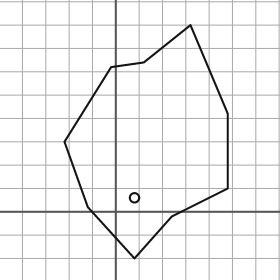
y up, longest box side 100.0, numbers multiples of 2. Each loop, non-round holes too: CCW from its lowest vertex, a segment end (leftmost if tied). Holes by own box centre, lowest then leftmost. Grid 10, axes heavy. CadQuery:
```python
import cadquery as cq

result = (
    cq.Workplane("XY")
    .moveTo(8.0, -20.0)
    .lineTo(24.0, -2.0)
    .lineTo(48.0, 10.0)
    .lineTo(48.0, 42.0)
    .lineTo(32.0, 80.0)
    .lineTo(12.0, 64.0)
    .lineTo(-2.0, 62.0)
    .lineTo(-22.0, 30.0)
    .lineTo(-12.0, 2.0)
    .close()
    .moveTo(8.0, 6.0)
    .circle(2.0)
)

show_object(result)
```